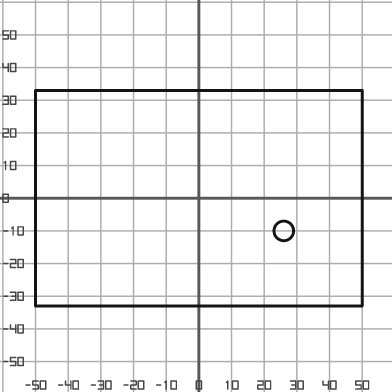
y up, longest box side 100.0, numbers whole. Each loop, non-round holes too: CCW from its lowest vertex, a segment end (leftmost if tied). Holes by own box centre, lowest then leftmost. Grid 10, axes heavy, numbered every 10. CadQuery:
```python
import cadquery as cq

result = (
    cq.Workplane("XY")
    .moveTo(-50.0, -33.0)
    .lineTo(50.0, -33.0)
    .lineTo(50.0, 33.0)
    .lineTo(-50.0, 33.0)
    .close()
    .moveTo(26.0, -10.0)
    .circle(3.0)
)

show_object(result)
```